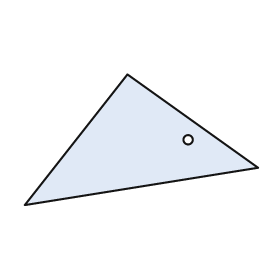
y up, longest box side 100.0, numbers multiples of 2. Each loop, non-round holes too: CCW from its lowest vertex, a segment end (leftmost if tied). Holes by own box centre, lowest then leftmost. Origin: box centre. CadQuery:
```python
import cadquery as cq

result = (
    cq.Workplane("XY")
    .moveTo(-50.0, -28.0)
    .lineTo(50.0, -12.0)
    .lineTo(-6.0, 28.0)
    .close()
    .moveTo(20.0, 0.0)
    .circle(2.0)
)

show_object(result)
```